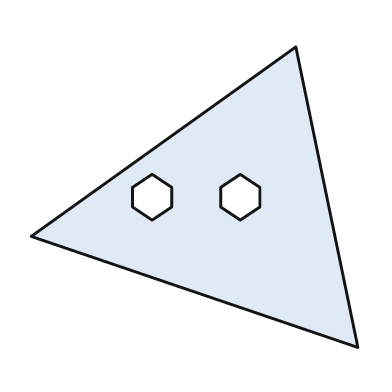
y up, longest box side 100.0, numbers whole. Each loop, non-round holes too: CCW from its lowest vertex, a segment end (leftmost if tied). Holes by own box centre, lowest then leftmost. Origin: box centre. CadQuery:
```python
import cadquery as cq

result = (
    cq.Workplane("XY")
    .moveTo(50.0, -46.0)
    .lineTo(31.0, 46.0)
    .lineTo(-50.0, -12.0)
    .close()
    .moveTo(-13.0, -7.0)
    .lineTo(-7.0, -3.0)
    .lineTo(-7.0, 3.0)
    .lineTo(-13.0, 7.0)
    .lineTo(-19.0, 3.0)
    .lineTo(-19.0, -3.0)
    .close()
    .moveTo(14.0, -7.0)
    .lineTo(20.0, -3.0)
    .lineTo(20.0, 3.0)
    .lineTo(14.0, 7.0)
    .lineTo(8.0, 3.0)
    .lineTo(8.0, -3.0)
    .close()
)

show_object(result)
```